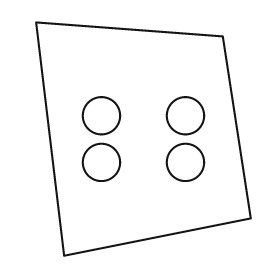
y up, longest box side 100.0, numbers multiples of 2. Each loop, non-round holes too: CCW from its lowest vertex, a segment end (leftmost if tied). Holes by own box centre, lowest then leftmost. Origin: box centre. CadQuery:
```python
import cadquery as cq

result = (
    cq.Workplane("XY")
    .moveTo(-34.0, -50.0)
    .lineTo(46.0, -34.0)
    .lineTo(34.0, 44.0)
    .lineTo(-46.0, 50.0)
    .close()
    .moveTo(-18.0, -10.0)
    .circle(8.0)
    .moveTo(18.0, -10.0)
    .circle(8.0)
    .moveTo(-18.0, 10.0)
    .circle(8.0)
    .moveTo(18.0, 10.0)
    .circle(8.0)
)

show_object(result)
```